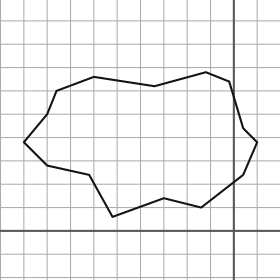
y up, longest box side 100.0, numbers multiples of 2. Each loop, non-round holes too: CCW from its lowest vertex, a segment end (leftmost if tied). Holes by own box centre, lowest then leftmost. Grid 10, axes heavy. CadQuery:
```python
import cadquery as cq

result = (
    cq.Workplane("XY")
    .moveTo(-52.0, 6.0)
    .lineTo(-30.0, 14.0)
    .lineTo(-14.0, 10.0)
    .lineTo(4.0, 24.0)
    .lineTo(10.0, 38.0)
    .lineTo(4.0, 44.0)
    .lineTo(-2.0, 64.0)
    .lineTo(-12.0, 68.0)
    .lineTo(-34.0, 62.0)
    .lineTo(-60.0, 66.0)
    .lineTo(-76.0, 60.0)
    .lineTo(-80.0, 50.0)
    .lineTo(-90.0, 38.0)
    .lineTo(-80.0, 28.0)
    .lineTo(-62.0, 24.0)
    .close()
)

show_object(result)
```